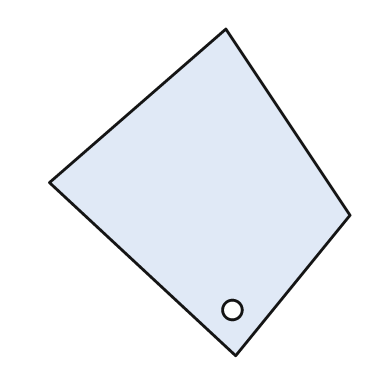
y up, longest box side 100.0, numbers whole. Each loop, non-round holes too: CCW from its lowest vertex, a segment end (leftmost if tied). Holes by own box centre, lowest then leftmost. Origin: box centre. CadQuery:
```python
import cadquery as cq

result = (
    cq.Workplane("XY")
    .moveTo(11.0, -50.0)
    .lineTo(46.0, -7.0)
    .lineTo(8.0, 50.0)
    .lineTo(-46.0, 3.0)
    .close()
    .moveTo(10.0, -36.0)
    .circle(3.0)
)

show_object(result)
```